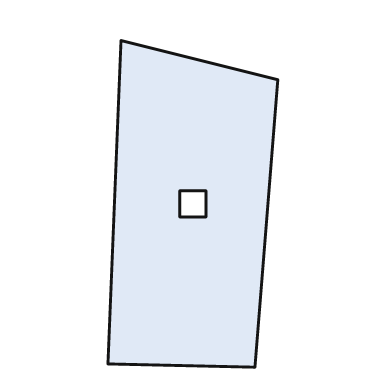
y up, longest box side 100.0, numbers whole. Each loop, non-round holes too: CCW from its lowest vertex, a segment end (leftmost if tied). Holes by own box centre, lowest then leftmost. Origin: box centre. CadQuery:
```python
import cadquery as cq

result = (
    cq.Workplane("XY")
    .moveTo(19.0, -50.0)
    .lineTo(26.0, 38.0)
    .lineTo(-22.0, 50.0)
    .lineTo(-26.0, -49.0)
    .close()
    .moveTo(-4.0, -4.0)
    .lineTo(4.0, -4.0)
    .lineTo(4.0, 4.0)
    .lineTo(-4.0, 4.0)
    .close()
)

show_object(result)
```